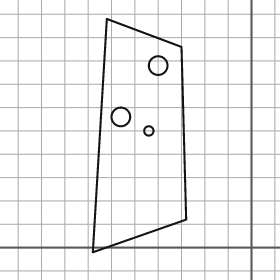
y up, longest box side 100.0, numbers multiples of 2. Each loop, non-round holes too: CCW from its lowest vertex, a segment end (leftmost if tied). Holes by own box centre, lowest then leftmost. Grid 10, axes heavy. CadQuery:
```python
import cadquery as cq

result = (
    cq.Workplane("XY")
    .moveTo(-68.0, -2.0)
    .lineTo(-28.0, 12.0)
    .lineTo(-30.0, 86.0)
    .lineTo(-62.0, 98.0)
    .close()
    .moveTo(-44.0, 50.0)
    .circle(2.0)
    .moveTo(-56.0, 56.0)
    .circle(4.0)
    .moveTo(-40.0, 78.0)
    .circle(4.0)
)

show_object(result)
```